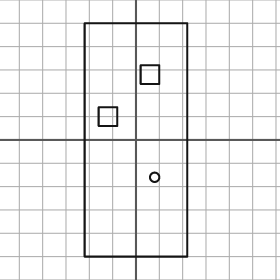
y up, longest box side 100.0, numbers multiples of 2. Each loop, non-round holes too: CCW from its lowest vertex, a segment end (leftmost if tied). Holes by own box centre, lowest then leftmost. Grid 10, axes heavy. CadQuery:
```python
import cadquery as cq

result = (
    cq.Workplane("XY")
    .moveTo(-22.0, -50.0)
    .lineTo(22.0, -50.0)
    .lineTo(22.0, 50.0)
    .lineTo(-22.0, 50.0)
    .close()
    .moveTo(8.0, -16.0)
    .circle(2.0)
    .moveTo(-16.0, 6.0)
    .lineTo(-8.0, 6.0)
    .lineTo(-8.0, 14.0)
    .lineTo(-16.0, 14.0)
    .close()
    .moveTo(2.0, 24.0)
    .lineTo(10.0, 24.0)
    .lineTo(10.0, 32.0)
    .lineTo(2.0, 32.0)
    .close()
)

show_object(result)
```